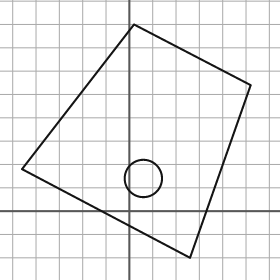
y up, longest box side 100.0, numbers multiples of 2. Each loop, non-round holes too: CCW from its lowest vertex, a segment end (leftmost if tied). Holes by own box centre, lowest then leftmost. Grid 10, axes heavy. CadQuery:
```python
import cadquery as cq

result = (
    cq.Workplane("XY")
    .moveTo(26.0, -20.0)
    .lineTo(52.0, 54.0)
    .lineTo(2.0, 80.0)
    .lineTo(-46.0, 18.0)
    .close()
    .moveTo(6.0, 14.0)
    .circle(8.0)
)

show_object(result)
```